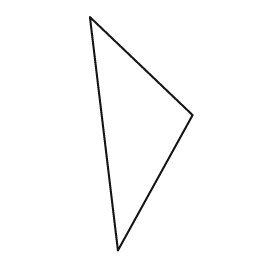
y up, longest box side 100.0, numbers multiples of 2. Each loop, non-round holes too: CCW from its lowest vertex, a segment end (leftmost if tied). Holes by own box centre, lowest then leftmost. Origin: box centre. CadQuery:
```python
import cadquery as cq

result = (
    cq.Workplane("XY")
    .moveTo(-10.0, -50.0)
    .lineTo(22.0, 8.0)
    .lineTo(-22.0, 50.0)
    .close()
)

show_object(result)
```